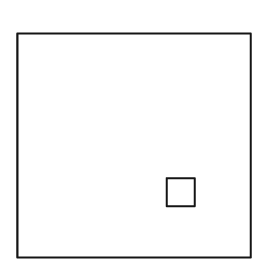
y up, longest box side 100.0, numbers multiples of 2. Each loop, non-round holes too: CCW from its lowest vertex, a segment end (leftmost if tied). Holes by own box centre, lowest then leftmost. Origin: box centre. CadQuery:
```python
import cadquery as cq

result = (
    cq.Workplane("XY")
    .moveTo(-50.0, -48.0)
    .lineTo(50.0, -48.0)
    .lineTo(50.0, 48.0)
    .lineTo(-50.0, 48.0)
    .close()
    .moveTo(14.0, -26.0)
    .lineTo(26.0, -26.0)
    .lineTo(26.0, -14.0)
    .lineTo(14.0, -14.0)
    .close()
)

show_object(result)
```